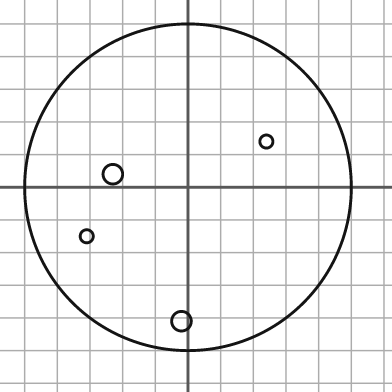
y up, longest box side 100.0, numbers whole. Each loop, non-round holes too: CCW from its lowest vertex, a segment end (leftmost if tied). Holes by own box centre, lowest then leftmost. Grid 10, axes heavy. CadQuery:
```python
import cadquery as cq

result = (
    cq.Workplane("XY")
    .moveTo(0.0, 0.0)
    .circle(50.0)
    .moveTo(-2.0, -41.0)
    .circle(3.0)
    .moveTo(-31.0, -15.0)
    .circle(2.0)
    .moveTo(-23.0, 4.0)
    .circle(3.0)
    .moveTo(24.0, 14.0)
    .circle(2.0)
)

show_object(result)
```